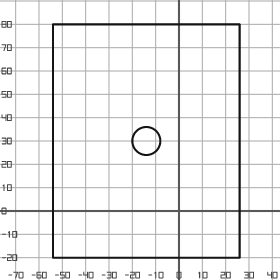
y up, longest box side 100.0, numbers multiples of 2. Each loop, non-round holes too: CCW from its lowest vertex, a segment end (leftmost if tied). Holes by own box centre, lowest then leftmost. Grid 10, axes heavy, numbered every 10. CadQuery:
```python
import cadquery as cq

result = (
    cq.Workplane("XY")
    .moveTo(-54.0, -20.0)
    .lineTo(26.0, -20.0)
    .lineTo(26.0, 80.0)
    .lineTo(-54.0, 80.0)
    .close()
    .moveTo(-14.0, 30.0)
    .circle(6.0)
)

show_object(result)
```